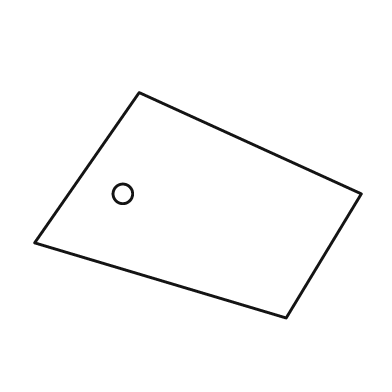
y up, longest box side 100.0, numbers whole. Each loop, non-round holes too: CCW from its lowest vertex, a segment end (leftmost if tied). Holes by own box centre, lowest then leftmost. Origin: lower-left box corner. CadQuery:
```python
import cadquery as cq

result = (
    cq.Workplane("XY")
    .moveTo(77.0, 0.0)
    .lineTo(100.0, 38.0)
    .lineTo(32.0, 69.0)
    .lineTo(0.0, 23.0)
    .close()
    .moveTo(27.0, 38.0)
    .circle(3.0)
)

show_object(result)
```